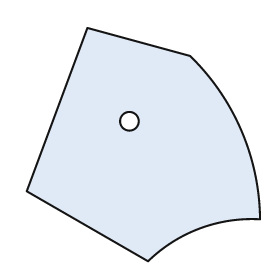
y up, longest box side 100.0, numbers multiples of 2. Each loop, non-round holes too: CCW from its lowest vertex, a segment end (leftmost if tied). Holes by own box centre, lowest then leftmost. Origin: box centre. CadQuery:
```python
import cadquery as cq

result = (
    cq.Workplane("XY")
    .moveTo(2.0, -50.0)
    .threePointArc((24.0, -36.0), (50.0, -32.0))
    .threePointArc((42.0, 6.0), (20.0, 38.0))
    .lineTo(-24.0, 50.0)
    .lineTo(-50.0, -20.0)
    .close()
    .moveTo(-6.0, 10.0)
    .circle(4.0)
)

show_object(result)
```